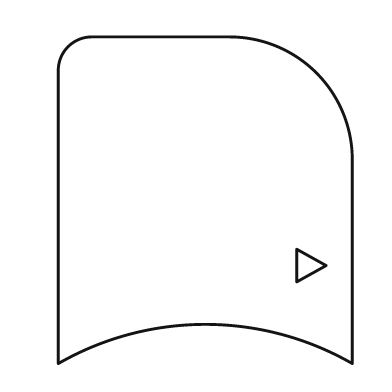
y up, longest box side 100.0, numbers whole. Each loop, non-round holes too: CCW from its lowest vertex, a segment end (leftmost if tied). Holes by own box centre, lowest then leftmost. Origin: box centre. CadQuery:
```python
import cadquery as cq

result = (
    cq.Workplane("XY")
    .moveTo(-45.0, -50.0)
    .threePointArc((0.0, -38.0), (45.0, -50.0))
    .lineTo(45.0, 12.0)
    .threePointArc((34.0, 39.0), (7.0, 50.0))
    .lineTo(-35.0, 50.0)
    .threePointArc((-42.0, 47.0), (-45.0, 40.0))
    .close()
    .moveTo(28.0, -25.0)
    .lineTo(37.0, -20.0)
    .lineTo(28.0, -15.0)
    .close()
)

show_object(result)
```